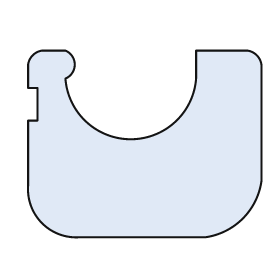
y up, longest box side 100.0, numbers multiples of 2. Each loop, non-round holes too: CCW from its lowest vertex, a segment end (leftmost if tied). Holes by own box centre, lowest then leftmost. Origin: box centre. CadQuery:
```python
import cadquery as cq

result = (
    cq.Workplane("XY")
    .moveTo(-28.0, -40.0)
    .lineTo(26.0, -40.0)
    .threePointArc((42.0, -32.0), (50.0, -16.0))
    .lineTo(50.0, 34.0)
    .threePointArc((48.0, 38.0), (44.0, 40.0))
    .lineTo(22.0, 40.0)
    .lineTo(22.0, 28.0)
    .threePointArc((-6.0, 2.0), (-34.0, 28.0))
    .threePointArc((-30.0, 34.0), (-34.0, 40.0))
    .lineTo(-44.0, 40.0)
    .threePointArc((-48.0, 38.0), (-50.0, 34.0))
    .lineTo(-50.0, 24.0)
    .lineTo(-46.0, 24.0)
    .lineTo(-46.0, 10.0)
    .lineTo(-50.0, 10.0)
    .lineTo(-50.0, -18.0)
    .threePointArc((-44.0, -34.0), (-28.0, -40.0))
    .close()
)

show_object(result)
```